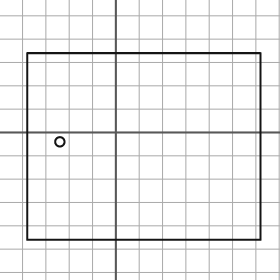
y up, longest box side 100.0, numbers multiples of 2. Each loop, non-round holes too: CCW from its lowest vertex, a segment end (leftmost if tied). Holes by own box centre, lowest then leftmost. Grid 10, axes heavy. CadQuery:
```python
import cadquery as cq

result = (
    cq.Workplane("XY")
    .moveTo(-38.0, -46.0)
    .lineTo(62.0, -46.0)
    .lineTo(62.0, 34.0)
    .lineTo(-38.0, 34.0)
    .close()
    .moveTo(-24.0, -4.0)
    .circle(2.0)
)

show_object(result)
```